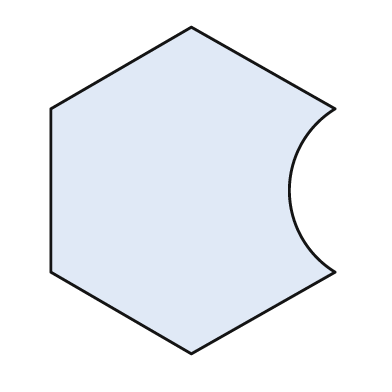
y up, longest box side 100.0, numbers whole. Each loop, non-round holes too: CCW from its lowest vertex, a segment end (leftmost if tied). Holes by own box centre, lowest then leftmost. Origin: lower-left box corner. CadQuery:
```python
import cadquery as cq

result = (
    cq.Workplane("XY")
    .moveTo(43.0, 0.0)
    .lineTo(87.0, 25.0)
    .threePointArc((73.0, 50.0), (87.0, 75.0))
    .lineTo(43.0, 100.0)
    .lineTo(0.0, 75.0)
    .lineTo(0.0, 25.0)
    .close()
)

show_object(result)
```